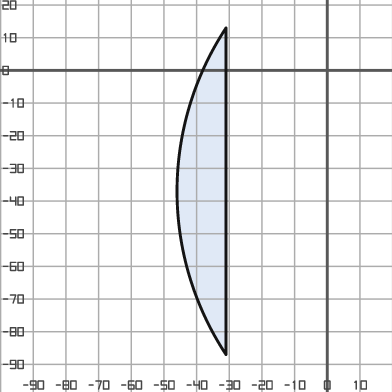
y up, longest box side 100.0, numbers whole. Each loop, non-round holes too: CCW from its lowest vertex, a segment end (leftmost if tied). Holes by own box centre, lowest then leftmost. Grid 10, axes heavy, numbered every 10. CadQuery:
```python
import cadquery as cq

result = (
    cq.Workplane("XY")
    .moveTo(-31.0, -87.0)
    .lineTo(-31.0, 13.0)
    .threePointArc((-46.0, -37.0), (-31.0, -87.0))
    .close()
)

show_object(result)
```